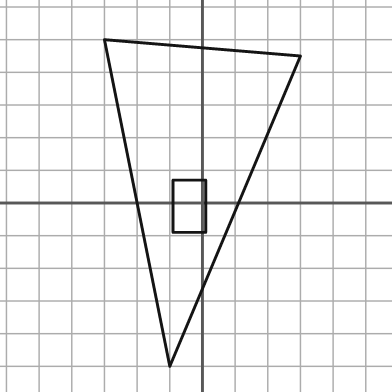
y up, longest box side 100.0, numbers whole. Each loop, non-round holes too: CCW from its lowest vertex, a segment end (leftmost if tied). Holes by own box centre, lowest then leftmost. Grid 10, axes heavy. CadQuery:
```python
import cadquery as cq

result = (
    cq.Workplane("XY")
    .moveTo(-10.0, -50.0)
    .lineTo(30.0, 45.0)
    .lineTo(-30.0, 50.0)
    .close()
    .moveTo(-9.0, -9.0)
    .lineTo(1.0, -9.0)
    .lineTo(1.0, 7.0)
    .lineTo(-9.0, 7.0)
    .close()
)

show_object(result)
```